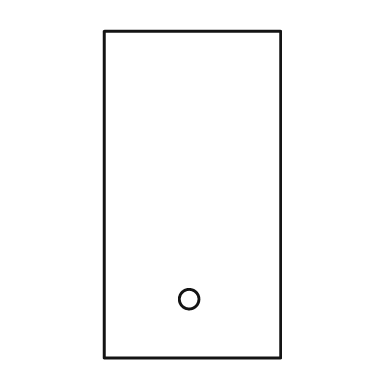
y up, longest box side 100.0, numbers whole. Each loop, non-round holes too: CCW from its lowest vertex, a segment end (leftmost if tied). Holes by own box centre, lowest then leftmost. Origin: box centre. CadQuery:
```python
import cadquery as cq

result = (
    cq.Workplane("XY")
    .moveTo(-27.0, -50.0)
    .lineTo(27.0, -50.0)
    .lineTo(27.0, 50.0)
    .lineTo(-27.0, 50.0)
    .close()
    .moveTo(-1.0, -32.0)
    .circle(3.0)
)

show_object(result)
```